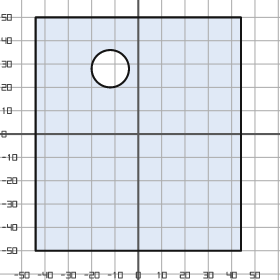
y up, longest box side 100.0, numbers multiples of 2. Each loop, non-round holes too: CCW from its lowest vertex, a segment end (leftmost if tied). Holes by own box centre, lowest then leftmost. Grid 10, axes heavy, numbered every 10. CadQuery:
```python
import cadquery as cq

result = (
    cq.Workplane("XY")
    .moveTo(-44.0, -50.0)
    .lineTo(44.0, -50.0)
    .lineTo(44.0, 50.0)
    .lineTo(-44.0, 50.0)
    .close()
    .moveTo(-12.0, 28.0)
    .circle(8.0)
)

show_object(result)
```